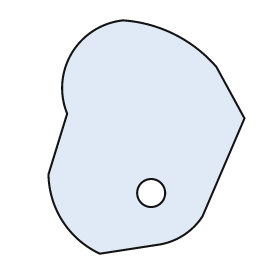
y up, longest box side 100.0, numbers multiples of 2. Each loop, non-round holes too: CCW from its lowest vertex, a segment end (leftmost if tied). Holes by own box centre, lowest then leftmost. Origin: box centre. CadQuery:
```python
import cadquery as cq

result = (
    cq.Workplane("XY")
    .moveTo(-20.0, -50.0)
    .lineTo(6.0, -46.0)
    .threePointArc((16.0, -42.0), (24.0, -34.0))
    .lineTo(42.0, 8.0)
    .lineTo(30.0, 30.0)
    .threePointArc((12.0, 44.0), (-10.0, 50.0))
    .threePointArc((-32.0, 36.0), (-34.0, 10.0))
    .lineTo(-42.0, -16.0)
    .threePointArc((-36.0, -36.0), (-20.0, -50.0))
    .close()
    .moveTo(2.0, -24.0)
    .circle(6.0)
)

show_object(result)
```